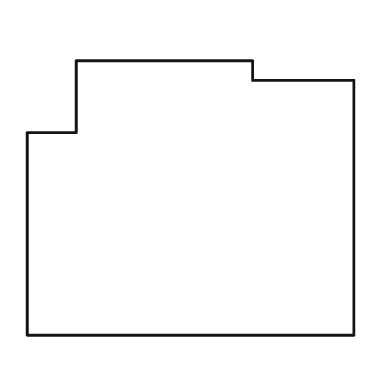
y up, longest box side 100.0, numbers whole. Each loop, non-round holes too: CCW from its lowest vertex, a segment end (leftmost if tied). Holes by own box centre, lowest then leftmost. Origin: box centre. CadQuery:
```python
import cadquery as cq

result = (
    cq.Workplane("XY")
    .moveTo(-50.0, -42.0)
    .lineTo(50.0, -42.0)
    .lineTo(50.0, 36.0)
    .lineTo(19.0, 36.0)
    .lineTo(19.0, 42.0)
    .lineTo(-35.0, 42.0)
    .lineTo(-35.0, 20.0)
    .lineTo(-50.0, 20.0)
    .close()
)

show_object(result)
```